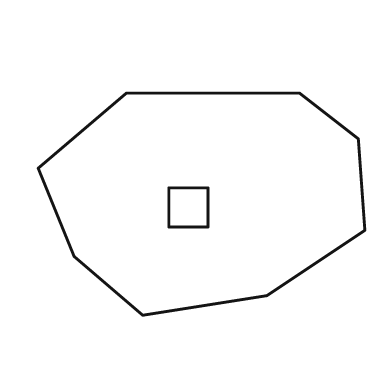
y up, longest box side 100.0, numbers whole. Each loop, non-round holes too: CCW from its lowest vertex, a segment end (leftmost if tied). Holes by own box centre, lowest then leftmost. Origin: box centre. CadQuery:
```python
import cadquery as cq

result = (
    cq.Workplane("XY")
    .moveTo(-18.0, -34.0)
    .lineTo(20.0, -28.0)
    .lineTo(50.0, -8.0)
    .lineTo(48.0, 20.0)
    .lineTo(30.0, 34.0)
    .lineTo(-23.0, 34.0)
    .lineTo(-50.0, 11.0)
    .lineTo(-39.0, -16.0)
    .close()
    .moveTo(-10.0, -7.0)
    .lineTo(2.0, -7.0)
    .lineTo(2.0, 5.0)
    .lineTo(-10.0, 5.0)
    .close()
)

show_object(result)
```